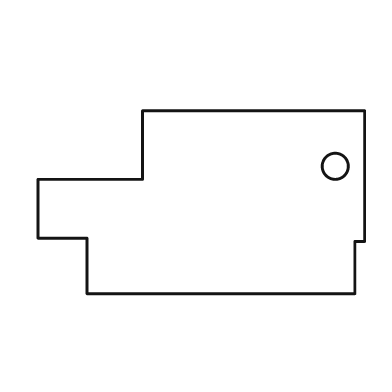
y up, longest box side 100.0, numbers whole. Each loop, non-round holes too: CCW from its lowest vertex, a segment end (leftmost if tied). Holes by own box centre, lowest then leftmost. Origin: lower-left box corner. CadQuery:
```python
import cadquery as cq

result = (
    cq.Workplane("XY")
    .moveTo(15.0, 0.0)
    .lineTo(97.0, 0.0)
    .lineTo(97.0, 16.0)
    .lineTo(100.0, 16.0)
    .lineTo(100.0, 56.0)
    .lineTo(32.0, 56.0)
    .lineTo(32.0, 35.0)
    .lineTo(0.0, 35.0)
    .lineTo(0.0, 17.0)
    .lineTo(15.0, 17.0)
    .close()
    .moveTo(91.0, 39.0)
    .circle(4.0)
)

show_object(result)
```